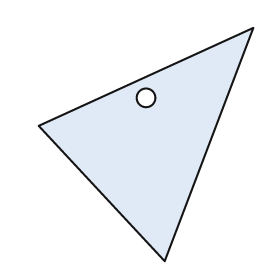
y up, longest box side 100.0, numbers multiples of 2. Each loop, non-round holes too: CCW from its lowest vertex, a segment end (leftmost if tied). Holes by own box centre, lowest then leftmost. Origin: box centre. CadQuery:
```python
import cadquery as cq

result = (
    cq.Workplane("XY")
    .moveTo(8.0, -50.0)
    .lineTo(46.0, 50.0)
    .lineTo(-46.0, 8.0)
    .close()
    .moveTo(0.0, 20.0)
    .circle(4.0)
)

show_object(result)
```